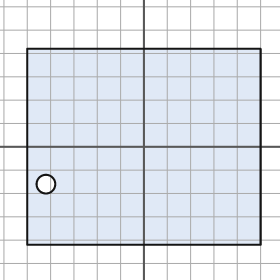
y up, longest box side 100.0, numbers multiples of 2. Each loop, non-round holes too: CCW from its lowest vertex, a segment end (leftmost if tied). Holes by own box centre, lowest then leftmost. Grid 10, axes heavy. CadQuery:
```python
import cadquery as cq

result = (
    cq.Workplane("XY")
    .moveTo(-50.0, -42.0)
    .lineTo(50.0, -42.0)
    .lineTo(50.0, 42.0)
    .lineTo(-50.0, 42.0)
    .close()
    .moveTo(-42.0, -16.0)
    .circle(4.0)
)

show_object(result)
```